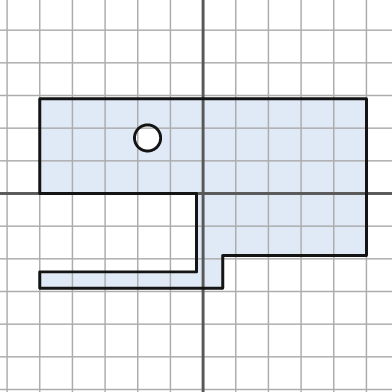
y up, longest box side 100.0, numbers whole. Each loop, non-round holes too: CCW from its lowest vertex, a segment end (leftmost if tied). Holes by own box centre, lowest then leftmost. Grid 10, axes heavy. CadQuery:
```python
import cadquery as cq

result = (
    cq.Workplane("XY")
    .moveTo(-50.0, -29.0)
    .lineTo(6.0, -29.0)
    .lineTo(6.0, -19.0)
    .lineTo(50.0, -19.0)
    .lineTo(50.0, 29.0)
    .lineTo(-50.0, 29.0)
    .lineTo(-50.0, 0.0)
    .lineTo(-2.0, 0.0)
    .lineTo(-2.0, -24.0)
    .lineTo(-50.0, -24.0)
    .close()
    .moveTo(-17.0, 17.0)
    .circle(4.0)
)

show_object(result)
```